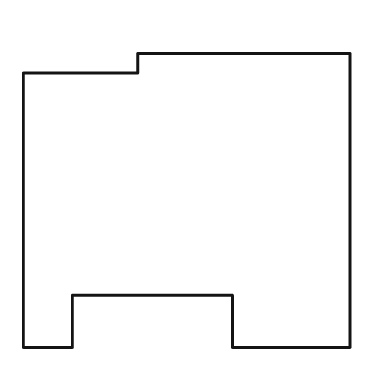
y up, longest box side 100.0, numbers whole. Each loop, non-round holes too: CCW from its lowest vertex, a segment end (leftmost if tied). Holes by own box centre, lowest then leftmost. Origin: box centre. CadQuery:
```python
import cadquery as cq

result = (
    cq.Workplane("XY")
    .moveTo(-50.0, -45.0)
    .lineTo(-35.0, -45.0)
    .lineTo(-35.0, -29.0)
    .lineTo(14.0, -29.0)
    .lineTo(14.0, -45.0)
    .lineTo(50.0, -45.0)
    .lineTo(50.0, 45.0)
    .lineTo(-15.0, 45.0)
    .lineTo(-15.0, 39.0)
    .lineTo(-50.0, 39.0)
    .close()
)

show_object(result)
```